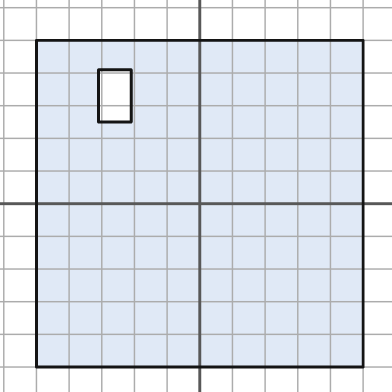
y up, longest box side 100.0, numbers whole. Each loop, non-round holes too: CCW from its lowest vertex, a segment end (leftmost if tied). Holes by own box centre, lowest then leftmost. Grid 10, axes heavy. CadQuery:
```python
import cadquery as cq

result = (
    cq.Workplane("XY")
    .moveTo(-50.0, -50.0)
    .lineTo(50.0, -50.0)
    .lineTo(50.0, 50.0)
    .lineTo(-50.0, 50.0)
    .close()
    .moveTo(-31.0, 25.0)
    .lineTo(-21.0, 25.0)
    .lineTo(-21.0, 41.0)
    .lineTo(-31.0, 41.0)
    .close()
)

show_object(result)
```